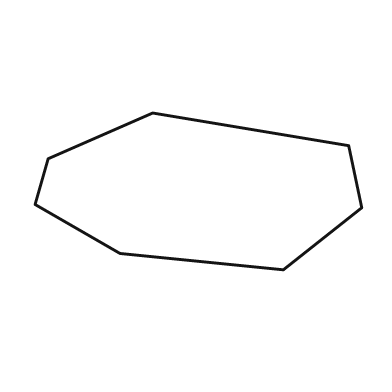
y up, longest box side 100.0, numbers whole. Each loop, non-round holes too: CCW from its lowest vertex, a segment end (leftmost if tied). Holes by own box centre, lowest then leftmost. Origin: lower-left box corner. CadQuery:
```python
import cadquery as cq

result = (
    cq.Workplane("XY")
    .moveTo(76.0, 0.0)
    .lineTo(100.0, 19.0)
    .lineTo(96.0, 38.0)
    .lineTo(36.0, 48.0)
    .lineTo(4.0, 34.0)
    .lineTo(0.0, 20.0)
    .lineTo(26.0, 5.0)
    .close()
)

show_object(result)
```